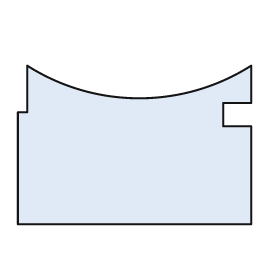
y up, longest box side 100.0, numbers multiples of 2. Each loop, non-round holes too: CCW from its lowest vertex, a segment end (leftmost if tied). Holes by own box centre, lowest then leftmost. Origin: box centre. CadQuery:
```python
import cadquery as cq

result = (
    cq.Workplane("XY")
    .moveTo(-50.0, -34.0)
    .lineTo(50.0, -34.0)
    .lineTo(50.0, 8.0)
    .lineTo(38.0, 8.0)
    .lineTo(38.0, 18.0)
    .lineTo(50.0, 18.0)
    .lineTo(50.0, 34.0)
    .threePointArc((2.0, 20.0), (-46.0, 34.0))
    .lineTo(-46.0, 14.0)
    .lineTo(-50.0, 14.0)
    .close()
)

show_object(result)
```